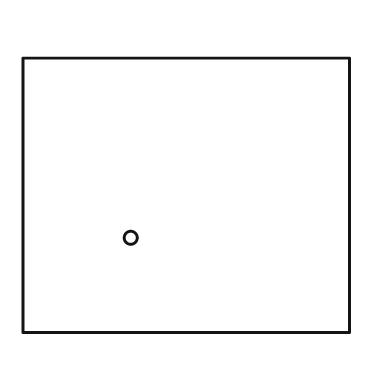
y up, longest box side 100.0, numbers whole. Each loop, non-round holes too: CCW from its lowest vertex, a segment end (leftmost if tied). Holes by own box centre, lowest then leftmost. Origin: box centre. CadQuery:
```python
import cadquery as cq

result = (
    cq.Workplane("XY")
    .moveTo(-50.0, -42.0)
    .lineTo(50.0, -42.0)
    .lineTo(50.0, 42.0)
    .lineTo(-50.0, 42.0)
    .close()
    .moveTo(-17.0, -13.0)
    .circle(2.0)
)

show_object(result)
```